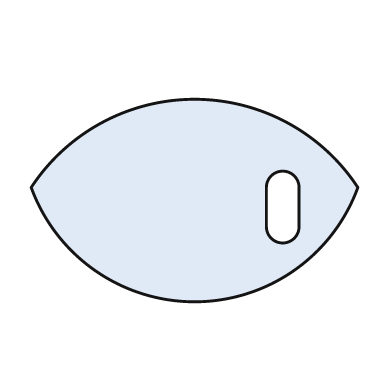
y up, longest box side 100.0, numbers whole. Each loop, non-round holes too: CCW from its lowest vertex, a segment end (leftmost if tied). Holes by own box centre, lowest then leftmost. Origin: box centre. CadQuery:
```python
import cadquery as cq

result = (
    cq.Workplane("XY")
    .moveTo(-50.0, 4.0)
    .threePointArc((0.0, -31.0), (50.0, 4.0))
    .threePointArc((0.0, 31.0), (-50.0, 4.0))
    .close()
    .moveTo(22.0, -8.0)
    .threePointArc((27.0, -13.0), (32.0, -8.0))
    .lineTo(32.0, 4.0)
    .threePointArc((27.0, 9.0), (22.0, 4.0))
    .close()
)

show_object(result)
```